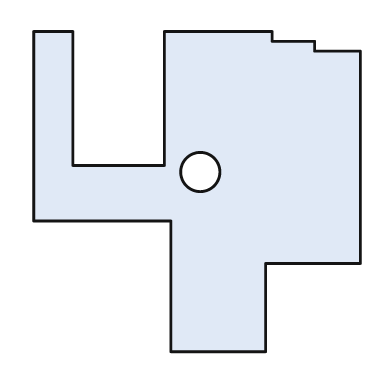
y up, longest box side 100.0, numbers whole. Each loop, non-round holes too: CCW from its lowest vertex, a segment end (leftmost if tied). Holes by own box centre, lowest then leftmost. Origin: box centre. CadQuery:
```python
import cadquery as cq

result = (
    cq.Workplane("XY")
    .moveTo(-8.0, -49.0)
    .lineTo(21.0, -49.0)
    .lineTo(21.0, -22.0)
    .lineTo(50.0, -22.0)
    .lineTo(50.0, 43.0)
    .lineTo(36.0, 43.0)
    .lineTo(36.0, 46.0)
    .lineTo(23.0, 46.0)
    .lineTo(23.0, 49.0)
    .lineTo(-10.0, 49.0)
    .lineTo(-10.0, 8.0)
    .lineTo(-38.0, 8.0)
    .lineTo(-38.0, 49.0)
    .lineTo(-50.0, 49.0)
    .lineTo(-50.0, -9.0)
    .lineTo(-8.0, -9.0)
    .close()
    .moveTo(1.0, 6.0)
    .circle(6.0)
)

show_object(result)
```